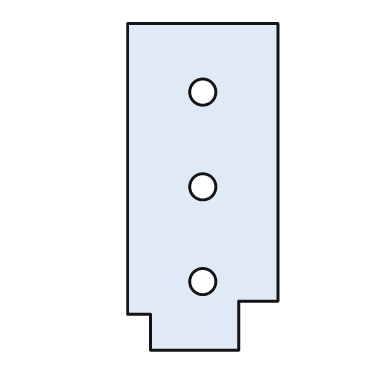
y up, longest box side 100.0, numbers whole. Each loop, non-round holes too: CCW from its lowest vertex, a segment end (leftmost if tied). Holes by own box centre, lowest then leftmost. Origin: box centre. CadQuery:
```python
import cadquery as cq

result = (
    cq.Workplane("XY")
    .moveTo(-16.0, -50.0)
    .lineTo(11.0, -50.0)
    .lineTo(11.0, -35.0)
    .lineTo(23.0, -35.0)
    .lineTo(23.0, 50.0)
    .lineTo(-23.0, 50.0)
    .lineTo(-23.0, -39.0)
    .lineTo(-16.0, -39.0)
    .close()
    .moveTo(0.0, -29.0)
    .circle(4.0)
    .moveTo(0.0, 0.0)
    .circle(4.0)
    .moveTo(0.0, 29.0)
    .circle(4.0)
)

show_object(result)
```